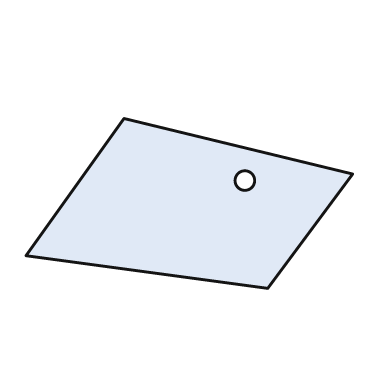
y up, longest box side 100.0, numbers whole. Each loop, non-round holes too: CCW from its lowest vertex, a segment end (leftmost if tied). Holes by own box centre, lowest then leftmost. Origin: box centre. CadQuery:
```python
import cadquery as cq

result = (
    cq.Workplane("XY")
    .moveTo(24.0, -26.0)
    .lineTo(50.0, 9.0)
    .lineTo(-20.0, 26.0)
    .lineTo(-50.0, -16.0)
    .close()
    .moveTo(17.0, 7.0)
    .circle(3.0)
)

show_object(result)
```